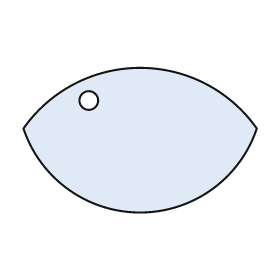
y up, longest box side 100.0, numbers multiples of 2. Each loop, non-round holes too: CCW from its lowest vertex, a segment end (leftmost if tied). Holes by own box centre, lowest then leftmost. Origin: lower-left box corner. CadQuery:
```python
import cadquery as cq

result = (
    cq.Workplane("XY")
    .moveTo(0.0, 36.0)
    .threePointArc((50.0, 0.0), (100.0, 36.0))
    .threePointArc((50.0, 62.0), (0.0, 36.0))
    .close()
    .moveTo(28.0, 48.0)
    .circle(4.0)
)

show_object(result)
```